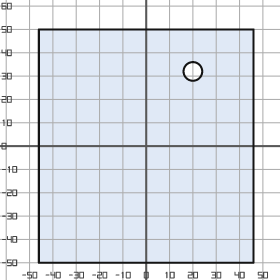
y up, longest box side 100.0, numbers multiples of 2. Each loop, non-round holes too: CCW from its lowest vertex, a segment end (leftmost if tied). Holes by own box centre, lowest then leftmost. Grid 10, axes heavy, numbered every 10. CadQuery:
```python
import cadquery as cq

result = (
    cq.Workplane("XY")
    .moveTo(-46.0, -50.0)
    .lineTo(46.0, -50.0)
    .lineTo(46.0, 50.0)
    .lineTo(-46.0, 50.0)
    .close()
    .moveTo(20.0, 32.0)
    .circle(4.0)
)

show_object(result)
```